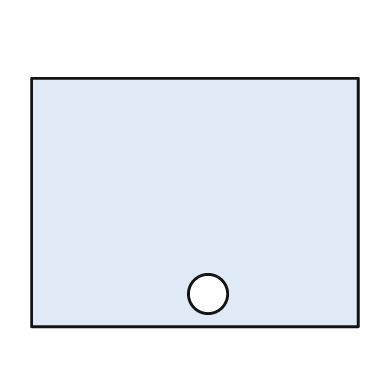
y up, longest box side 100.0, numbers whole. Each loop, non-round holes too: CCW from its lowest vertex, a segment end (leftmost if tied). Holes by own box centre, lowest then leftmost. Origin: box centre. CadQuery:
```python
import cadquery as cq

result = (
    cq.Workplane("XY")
    .moveTo(-50.0, -38.0)
    .lineTo(50.0, -38.0)
    .lineTo(50.0, 38.0)
    .lineTo(-50.0, 38.0)
    .close()
    .moveTo(4.0, -28.0)
    .circle(6.0)
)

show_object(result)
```